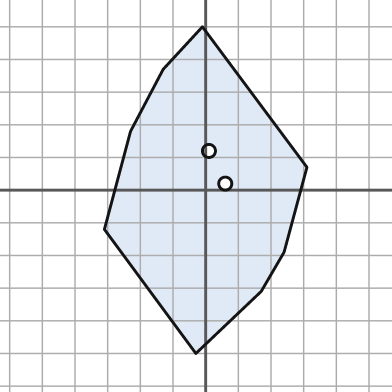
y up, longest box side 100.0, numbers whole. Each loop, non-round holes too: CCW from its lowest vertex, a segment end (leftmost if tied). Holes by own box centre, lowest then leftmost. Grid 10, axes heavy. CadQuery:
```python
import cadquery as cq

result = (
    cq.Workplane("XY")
    .moveTo(-3.0, -50.0)
    .lineTo(17.0, -31.0)
    .lineTo(24.0, -19.0)
    .lineTo(31.0, 7.0)
    .lineTo(-1.0, 50.0)
    .lineTo(-13.0, 37.0)
    .lineTo(-23.0, 18.0)
    .lineTo(-31.0, -12.0)
    .close()
    .moveTo(6.0, 2.0)
    .circle(2.0)
    .moveTo(1.0, 12.0)
    .circle(2.0)
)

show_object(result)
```